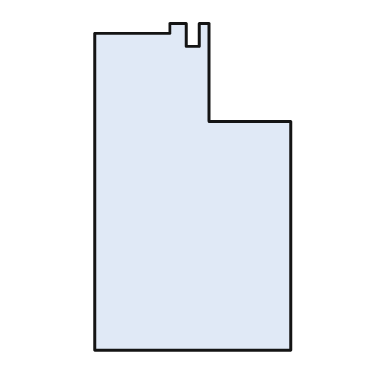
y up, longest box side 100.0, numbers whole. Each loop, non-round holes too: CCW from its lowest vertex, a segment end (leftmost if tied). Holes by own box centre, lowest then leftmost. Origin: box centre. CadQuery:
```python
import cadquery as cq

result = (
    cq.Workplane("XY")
    .moveTo(-30.0, -50.0)
    .lineTo(30.0, -50.0)
    .lineTo(30.0, 20.0)
    .lineTo(5.0, 20.0)
    .lineTo(5.0, 50.0)
    .lineTo(2.0, 50.0)
    .lineTo(2.0, 43.0)
    .lineTo(-2.0, 43.0)
    .lineTo(-2.0, 50.0)
    .lineTo(-7.0, 50.0)
    .lineTo(-7.0, 47.0)
    .lineTo(-30.0, 47.0)
    .close()
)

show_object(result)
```